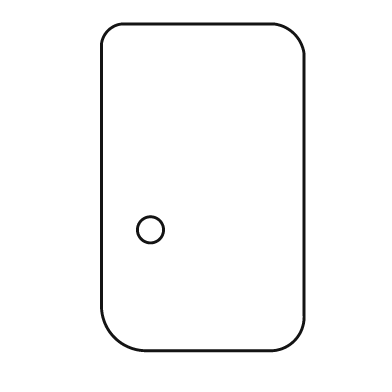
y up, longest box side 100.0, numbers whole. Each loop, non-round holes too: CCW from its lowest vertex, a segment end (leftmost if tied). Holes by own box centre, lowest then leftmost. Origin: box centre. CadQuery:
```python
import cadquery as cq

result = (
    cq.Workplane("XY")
    .moveTo(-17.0, -50.0)
    .lineTo(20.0, -50.0)
    .threePointArc((28.0, -47.0), (31.0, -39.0))
    .lineTo(31.0, 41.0)
    .threePointArc((28.0, 47.0), (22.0, 50.0))
    .lineTo(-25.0, 50.0)
    .threePointArc((-29.0, 48.0), (-31.0, 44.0))
    .lineTo(-31.0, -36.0)
    .threePointArc((-27.0, -46.0), (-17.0, -50.0))
    .close()
    .moveTo(-16.0, -13.0)
    .circle(4.0)
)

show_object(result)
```